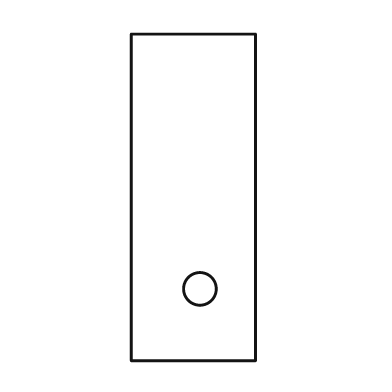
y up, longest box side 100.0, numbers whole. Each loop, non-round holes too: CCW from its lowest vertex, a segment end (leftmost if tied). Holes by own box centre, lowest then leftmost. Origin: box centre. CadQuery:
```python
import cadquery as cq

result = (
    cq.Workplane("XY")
    .moveTo(-19.0, -50.0)
    .lineTo(19.0, -50.0)
    .lineTo(19.0, 50.0)
    .lineTo(-19.0, 50.0)
    .close()
    .moveTo(2.0, -28.0)
    .circle(5.0)
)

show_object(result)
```